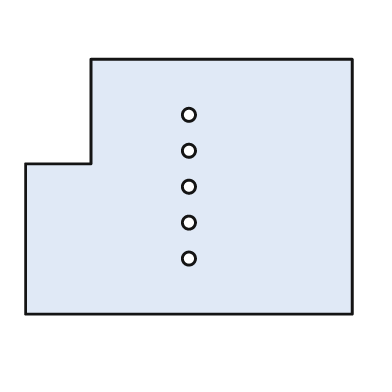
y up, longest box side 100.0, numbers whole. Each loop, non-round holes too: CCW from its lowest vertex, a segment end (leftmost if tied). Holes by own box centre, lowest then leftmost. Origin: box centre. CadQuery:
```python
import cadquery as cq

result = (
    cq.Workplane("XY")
    .moveTo(-50.0, -39.0)
    .lineTo(50.0, -39.0)
    .lineTo(50.0, 39.0)
    .lineTo(-30.0, 39.0)
    .lineTo(-30.0, 7.0)
    .lineTo(-50.0, 7.0)
    .close()
    .moveTo(0.0, -22.0)
    .circle(2.0)
    .moveTo(0.0, -11.0)
    .circle(2.0)
    .moveTo(0.0, 0.0)
    .circle(2.0)
    .moveTo(0.0, 11.0)
    .circle(2.0)
    .moveTo(0.0, 22.0)
    .circle(2.0)
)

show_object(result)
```